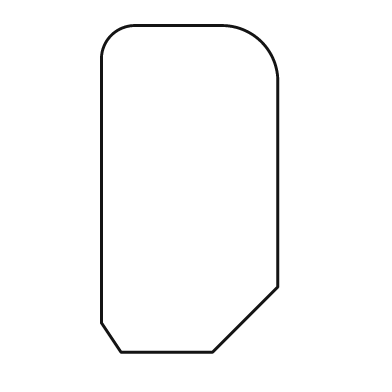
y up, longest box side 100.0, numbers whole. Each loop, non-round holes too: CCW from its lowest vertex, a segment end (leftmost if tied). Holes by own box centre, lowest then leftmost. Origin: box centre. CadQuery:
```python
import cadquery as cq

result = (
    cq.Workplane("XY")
    .moveTo(-21.0, -50.0)
    .lineTo(7.0, -50.0)
    .lineTo(27.0, -30.0)
    .lineTo(27.0, 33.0)
    .threePointArc((22.0, 45.0), (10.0, 50.0))
    .lineTo(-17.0, 50.0)
    .threePointArc((-24.0, 47.0), (-27.0, 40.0))
    .lineTo(-27.0, -41.0)
    .close()
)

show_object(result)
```